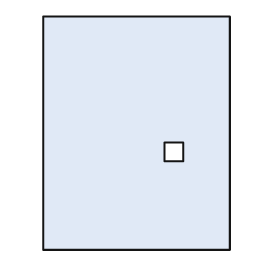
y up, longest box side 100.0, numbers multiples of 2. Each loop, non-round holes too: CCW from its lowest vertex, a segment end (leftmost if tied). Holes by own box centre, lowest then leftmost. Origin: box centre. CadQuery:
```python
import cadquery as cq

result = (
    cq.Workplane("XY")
    .moveTo(-40.0, -50.0)
    .lineTo(40.0, -50.0)
    .lineTo(40.0, 50.0)
    .lineTo(-40.0, 50.0)
    .close()
    .moveTo(12.0, -12.0)
    .lineTo(20.0, -12.0)
    .lineTo(20.0, -4.0)
    .lineTo(12.0, -4.0)
    .close()
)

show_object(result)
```